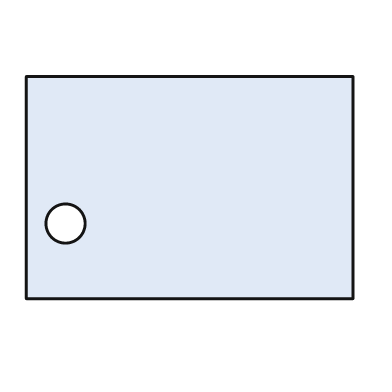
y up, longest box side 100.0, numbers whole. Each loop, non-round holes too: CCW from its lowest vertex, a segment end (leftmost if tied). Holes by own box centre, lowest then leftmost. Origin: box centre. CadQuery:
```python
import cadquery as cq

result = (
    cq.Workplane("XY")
    .moveTo(-50.0, -34.0)
    .lineTo(50.0, -34.0)
    .lineTo(50.0, 34.0)
    .lineTo(-50.0, 34.0)
    .close()
    .moveTo(-38.0, -11.0)
    .circle(6.0)
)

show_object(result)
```